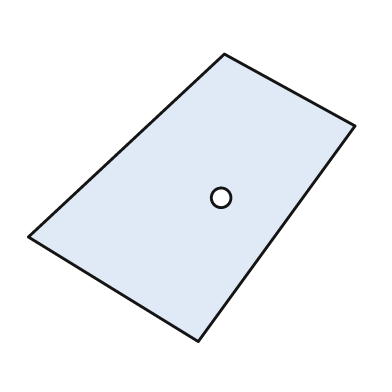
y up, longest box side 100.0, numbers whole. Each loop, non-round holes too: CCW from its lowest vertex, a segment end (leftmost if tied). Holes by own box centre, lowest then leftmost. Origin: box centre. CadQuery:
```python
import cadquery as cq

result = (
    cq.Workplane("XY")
    .moveTo(2.0, -44.0)
    .lineTo(50.0, 22.0)
    .lineTo(10.0, 44.0)
    .lineTo(-50.0, -12.0)
    .close()
    .moveTo(9.0, 0.0)
    .circle(3.0)
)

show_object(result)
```